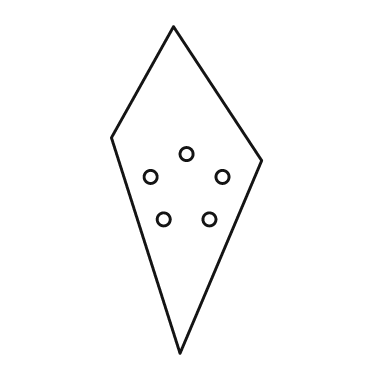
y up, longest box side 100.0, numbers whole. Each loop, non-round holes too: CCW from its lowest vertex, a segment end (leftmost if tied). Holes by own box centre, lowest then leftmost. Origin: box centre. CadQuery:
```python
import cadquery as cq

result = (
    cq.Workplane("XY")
    .moveTo(-2.0, -50.0)
    .lineTo(23.0, 9.0)
    .lineTo(-4.0, 50.0)
    .lineTo(-23.0, 16.0)
    .close()
    .moveTo(-7.0, -9.0)
    .circle(2.0)
    .moveTo(7.0, -9.0)
    .circle(2.0)
    .moveTo(-11.0, 4.0)
    .circle(2.0)
    .moveTo(11.0, 4.0)
    .circle(2.0)
    .moveTo(0.0, 11.0)
    .circle(2.0)
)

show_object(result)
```